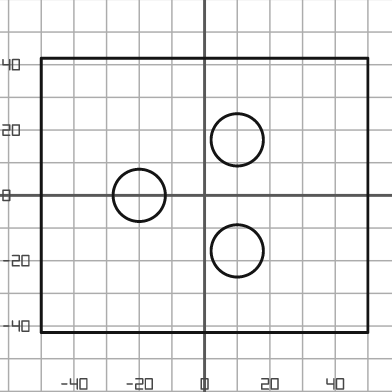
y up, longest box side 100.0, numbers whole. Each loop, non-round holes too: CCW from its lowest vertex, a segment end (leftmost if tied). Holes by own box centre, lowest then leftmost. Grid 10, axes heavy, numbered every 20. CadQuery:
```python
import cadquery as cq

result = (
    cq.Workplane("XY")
    .moveTo(-50.0, -42.0)
    .lineTo(50.0, -42.0)
    .lineTo(50.0, 42.0)
    .lineTo(-50.0, 42.0)
    .close()
    .moveTo(10.0, -17.0)
    .circle(8.0)
    .moveTo(-20.0, 0.0)
    .circle(8.0)
    .moveTo(10.0, 17.0)
    .circle(8.0)
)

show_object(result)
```